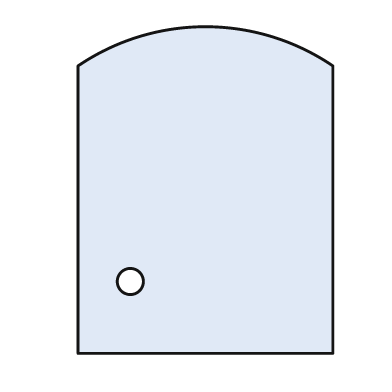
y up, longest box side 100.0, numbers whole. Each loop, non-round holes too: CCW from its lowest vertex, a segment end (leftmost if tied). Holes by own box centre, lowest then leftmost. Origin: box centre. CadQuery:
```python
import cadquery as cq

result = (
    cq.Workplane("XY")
    .moveTo(-39.0, -50.0)
    .lineTo(39.0, -50.0)
    .lineTo(39.0, 38.0)
    .threePointArc((0.0, 50.0), (-39.0, 38.0))
    .close()
    .moveTo(-23.0, -28.0)
    .circle(4.0)
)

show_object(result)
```